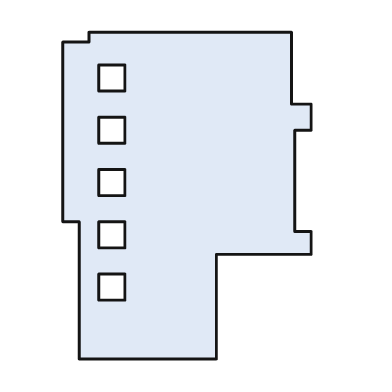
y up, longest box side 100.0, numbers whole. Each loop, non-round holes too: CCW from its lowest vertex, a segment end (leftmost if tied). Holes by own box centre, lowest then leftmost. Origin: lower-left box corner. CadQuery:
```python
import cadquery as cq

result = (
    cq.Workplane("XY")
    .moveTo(5.0, 0.0)
    .lineTo(47.0, 0.0)
    .lineTo(47.0, 32.0)
    .lineTo(76.0, 32.0)
    .lineTo(76.0, 39.0)
    .lineTo(71.0, 39.0)
    .lineTo(71.0, 70.0)
    .lineTo(76.0, 70.0)
    .lineTo(76.0, 78.0)
    .lineTo(70.0, 78.0)
    .lineTo(70.0, 100.0)
    .lineTo(8.0, 100.0)
    .lineTo(8.0, 97.0)
    .lineTo(0.0, 97.0)
    .lineTo(0.0, 42.0)
    .lineTo(5.0, 42.0)
    .close()
    .moveTo(11.0, 18.0)
    .lineTo(19.0, 18.0)
    .lineTo(19.0, 26.0)
    .lineTo(11.0, 26.0)
    .close()
    .moveTo(11.0, 34.0)
    .lineTo(19.0, 34.0)
    .lineTo(19.0, 42.0)
    .lineTo(11.0, 42.0)
    .close()
    .moveTo(11.0, 50.0)
    .lineTo(19.0, 50.0)
    .lineTo(19.0, 58.0)
    .lineTo(11.0, 58.0)
    .close()
    .moveTo(11.0, 66.0)
    .lineTo(19.0, 66.0)
    .lineTo(19.0, 74.0)
    .lineTo(11.0, 74.0)
    .close()
    .moveTo(11.0, 82.0)
    .lineTo(19.0, 82.0)
    .lineTo(19.0, 90.0)
    .lineTo(11.0, 90.0)
    .close()
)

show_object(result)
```